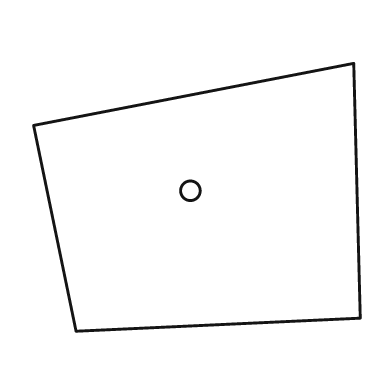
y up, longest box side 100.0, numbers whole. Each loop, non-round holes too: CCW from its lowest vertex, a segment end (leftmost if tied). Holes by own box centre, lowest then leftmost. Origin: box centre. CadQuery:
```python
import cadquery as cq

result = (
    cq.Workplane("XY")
    .moveTo(-37.0, -41.0)
    .lineTo(50.0, -37.0)
    .lineTo(48.0, 41.0)
    .lineTo(-50.0, 22.0)
    .close()
    .moveTo(-2.0, 2.0)
    .circle(3.0)
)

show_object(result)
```